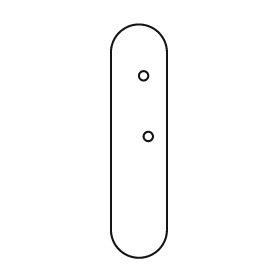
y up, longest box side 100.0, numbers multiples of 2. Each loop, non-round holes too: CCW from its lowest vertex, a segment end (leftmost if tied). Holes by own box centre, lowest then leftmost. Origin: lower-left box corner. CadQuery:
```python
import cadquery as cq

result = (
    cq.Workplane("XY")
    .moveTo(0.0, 12.0)
    .threePointArc((12.0, 0.0), (24.0, 12.0))
    .lineTo(24.0, 88.0)
    .threePointArc((12.0, 100.0), (0.0, 88.0))
    .close()
    .moveTo(16.0, 52.0)
    .circle(2.0)
    .moveTo(14.0, 78.0)
    .circle(2.0)
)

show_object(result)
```